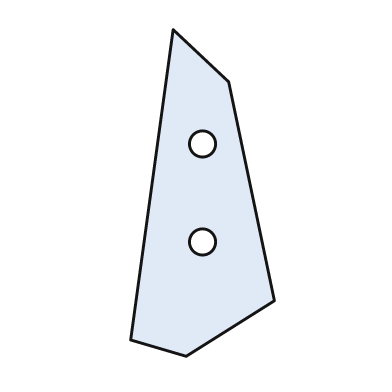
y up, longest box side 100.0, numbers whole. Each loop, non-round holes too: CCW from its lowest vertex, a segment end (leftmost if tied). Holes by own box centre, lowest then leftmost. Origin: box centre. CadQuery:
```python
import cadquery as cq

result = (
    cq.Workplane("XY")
    .moveTo(-5.0, -50.0)
    .lineTo(22.0, -33.0)
    .lineTo(8.0, 34.0)
    .lineTo(-9.0, 50.0)
    .lineTo(-22.0, -45.0)
    .close()
    .moveTo(0.0, -15.0)
    .circle(4.0)
    .moveTo(0.0, 15.0)
    .circle(4.0)
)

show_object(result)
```